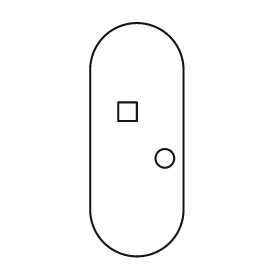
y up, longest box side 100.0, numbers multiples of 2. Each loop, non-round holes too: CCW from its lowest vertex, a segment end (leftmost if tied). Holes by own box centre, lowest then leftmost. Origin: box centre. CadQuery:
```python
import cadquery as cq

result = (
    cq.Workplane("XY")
    .moveTo(-20.0, -30.0)
    .threePointArc((0.0, -50.0), (20.0, -30.0))
    .lineTo(20.0, 30.0)
    .threePointArc((0.0, 50.0), (-20.0, 30.0))
    .close()
    .moveTo(12.0, -8.0)
    .circle(4.0)
    .moveTo(-8.0, 8.0)
    .lineTo(0.0, 8.0)
    .lineTo(0.0, 16.0)
    .lineTo(-8.0, 16.0)
    .close()
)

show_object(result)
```